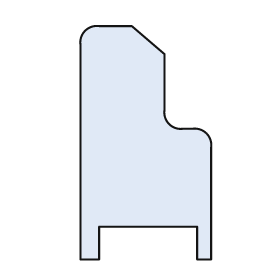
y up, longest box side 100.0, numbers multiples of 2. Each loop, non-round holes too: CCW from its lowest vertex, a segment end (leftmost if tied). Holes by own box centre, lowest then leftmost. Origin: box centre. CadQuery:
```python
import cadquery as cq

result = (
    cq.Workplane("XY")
    .moveTo(-28.0, -50.0)
    .lineTo(-20.0, -50.0)
    .lineTo(-20.0, -36.0)
    .lineTo(22.0, -36.0)
    .lineTo(22.0, -50.0)
    .lineTo(28.0, -50.0)
    .lineTo(28.0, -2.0)
    .threePointArc((26.0, 4.0), (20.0, 6.0))
    .lineTo(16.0, 6.0)
    .threePointArc((10.0, 8.0), (8.0, 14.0))
    .lineTo(8.0, 38.0)
    .lineTo(-6.0, 50.0)
    .lineTo(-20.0, 50.0)
    .threePointArc((-26.0, 48.0), (-28.0, 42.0))
    .close()
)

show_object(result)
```